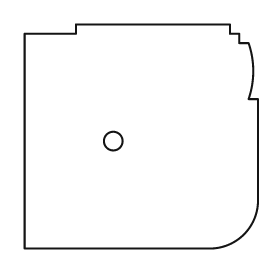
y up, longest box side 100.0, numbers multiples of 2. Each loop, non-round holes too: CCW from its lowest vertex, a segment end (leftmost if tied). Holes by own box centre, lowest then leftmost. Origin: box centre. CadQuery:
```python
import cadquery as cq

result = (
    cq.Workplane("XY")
    .moveTo(-50.0, -48.0)
    .lineTo(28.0, -48.0)
    .threePointArc((44.0, -42.0), (50.0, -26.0))
    .lineTo(50.0, 16.0)
    .lineTo(46.0, 16.0)
    .threePointArc((48.0, 28.0), (46.0, 40.0))
    .lineTo(42.0, 40.0)
    .lineTo(42.0, 44.0)
    .lineTo(38.0, 44.0)
    .lineTo(38.0, 48.0)
    .lineTo(-28.0, 48.0)
    .lineTo(-28.0, 44.0)
    .lineTo(-50.0, 44.0)
    .close()
    .moveTo(-12.0, -2.0)
    .circle(4.0)
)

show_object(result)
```